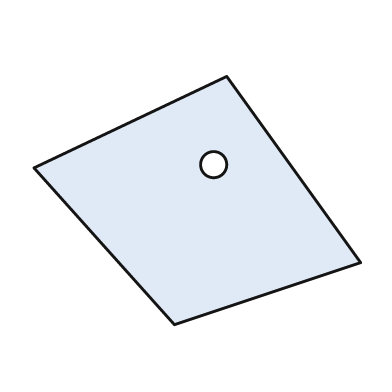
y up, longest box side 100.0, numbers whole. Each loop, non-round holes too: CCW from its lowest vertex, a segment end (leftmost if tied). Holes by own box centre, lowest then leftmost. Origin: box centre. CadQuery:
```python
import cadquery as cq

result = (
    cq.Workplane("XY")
    .moveTo(-7.0, -38.0)
    .lineTo(50.0, -19.0)
    .lineTo(9.0, 38.0)
    .lineTo(-50.0, 10.0)
    .close()
    .moveTo(5.0, 11.0)
    .circle(4.0)
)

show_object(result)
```